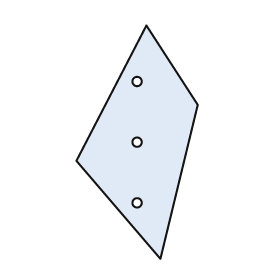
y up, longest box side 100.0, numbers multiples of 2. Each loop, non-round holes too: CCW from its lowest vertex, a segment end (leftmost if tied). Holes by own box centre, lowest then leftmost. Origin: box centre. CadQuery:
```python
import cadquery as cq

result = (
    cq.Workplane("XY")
    .moveTo(10.0, -50.0)
    .lineTo(26.0, 16.0)
    .lineTo(4.0, 50.0)
    .lineTo(-26.0, -8.0)
    .close()
    .moveTo(0.0, -26.0)
    .circle(2.0)
    .moveTo(0.0, 0.0)
    .circle(2.0)
    .moveTo(0.0, 26.0)
    .circle(2.0)
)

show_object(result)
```